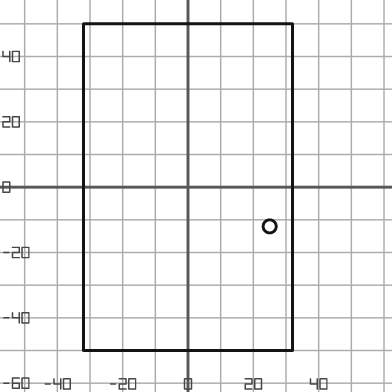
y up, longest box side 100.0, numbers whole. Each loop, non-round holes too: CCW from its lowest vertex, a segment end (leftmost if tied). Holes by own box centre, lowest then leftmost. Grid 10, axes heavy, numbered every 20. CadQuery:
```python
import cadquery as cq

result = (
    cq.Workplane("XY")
    .moveTo(-32.0, -50.0)
    .lineTo(32.0, -50.0)
    .lineTo(32.0, 50.0)
    .lineTo(-32.0, 50.0)
    .close()
    .moveTo(25.0, -12.0)
    .circle(2.0)
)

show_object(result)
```